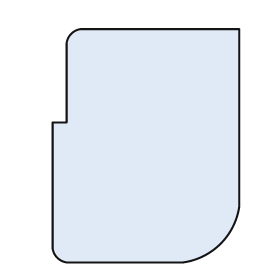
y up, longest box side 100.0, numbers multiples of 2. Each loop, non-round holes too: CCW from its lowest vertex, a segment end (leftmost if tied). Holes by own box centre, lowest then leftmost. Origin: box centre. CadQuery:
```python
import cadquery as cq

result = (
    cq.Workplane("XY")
    .moveTo(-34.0, -50.0)
    .lineTo(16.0, -50.0)
    .threePointArc((32.0, -42.0), (40.0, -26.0))
    .lineTo(40.0, 50.0)
    .lineTo(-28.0, 50.0)
    .threePointArc((-32.0, 48.0), (-34.0, 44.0))
    .lineTo(-34.0, 10.0)
    .lineTo(-40.0, 10.0)
    .lineTo(-40.0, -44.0)
    .threePointArc((-38.0, -48.0), (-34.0, -50.0))
    .close()
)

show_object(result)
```